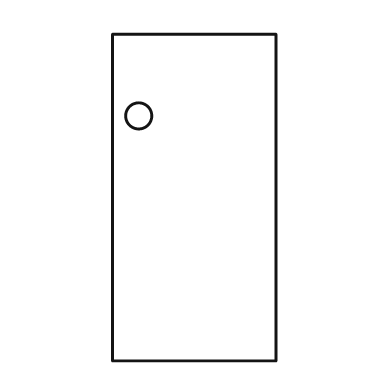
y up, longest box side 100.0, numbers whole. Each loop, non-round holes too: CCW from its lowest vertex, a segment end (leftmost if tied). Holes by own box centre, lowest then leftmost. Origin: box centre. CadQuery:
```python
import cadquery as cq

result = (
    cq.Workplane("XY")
    .moveTo(-25.0, -50.0)
    .lineTo(25.0, -50.0)
    .lineTo(25.0, 50.0)
    .lineTo(-25.0, 50.0)
    .close()
    .moveTo(-17.0, 25.0)
    .circle(4.0)
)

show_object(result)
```